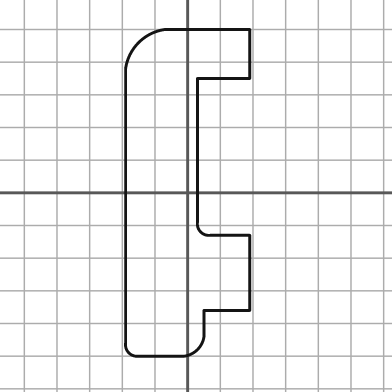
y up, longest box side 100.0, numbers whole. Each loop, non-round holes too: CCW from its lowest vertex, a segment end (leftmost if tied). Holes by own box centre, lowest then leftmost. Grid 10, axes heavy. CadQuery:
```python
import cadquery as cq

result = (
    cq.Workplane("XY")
    .moveTo(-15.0, -50.0)
    .lineTo(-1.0, -50.0)
    .threePointArc((3.0, -48.0), (5.0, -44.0))
    .lineTo(5.0, -36.0)
    .lineTo(19.0, -36.0)
    .lineTo(19.0, -13.0)
    .lineTo(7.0, -13.0)
    .threePointArc((4.0, -12.0), (3.0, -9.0))
    .lineTo(3.0, 35.0)
    .lineTo(19.0, 35.0)
    .lineTo(19.0, 50.0)
    .lineTo(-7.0, 50.0)
    .threePointArc((-15.0, 46.0), (-19.0, 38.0))
    .lineTo(-19.0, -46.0)
    .threePointArc((-18.0, -49.0), (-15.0, -50.0))
    .close()
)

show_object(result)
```